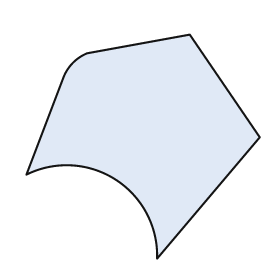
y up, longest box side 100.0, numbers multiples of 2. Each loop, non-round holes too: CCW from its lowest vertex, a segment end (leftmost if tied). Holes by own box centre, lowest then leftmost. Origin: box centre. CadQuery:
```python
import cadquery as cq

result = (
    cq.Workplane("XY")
    .moveTo(6.0, -48.0)
    .lineTo(50.0, 4.0)
    .lineTo(20.0, 48.0)
    .lineTo(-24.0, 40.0)
    .threePointArc((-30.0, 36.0), (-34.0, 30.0))
    .lineTo(-50.0, -12.0)
    .threePointArc((-12.0, -14.0), (6.0, -48.0))
    .close()
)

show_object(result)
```